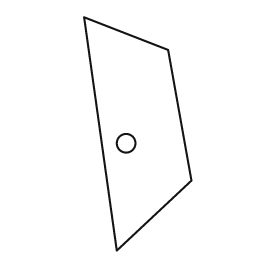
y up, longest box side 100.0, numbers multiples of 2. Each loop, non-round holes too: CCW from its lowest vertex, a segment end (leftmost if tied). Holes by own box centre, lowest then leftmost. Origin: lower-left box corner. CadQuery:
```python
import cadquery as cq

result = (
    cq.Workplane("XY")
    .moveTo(14.0, 0.0)
    .lineTo(46.0, 30.0)
    .lineTo(36.0, 86.0)
    .lineTo(0.0, 100.0)
    .close()
    .moveTo(18.0, 46.0)
    .circle(4.0)
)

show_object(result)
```